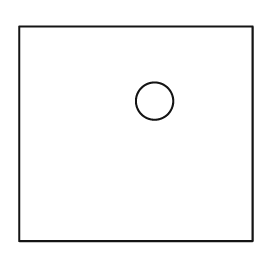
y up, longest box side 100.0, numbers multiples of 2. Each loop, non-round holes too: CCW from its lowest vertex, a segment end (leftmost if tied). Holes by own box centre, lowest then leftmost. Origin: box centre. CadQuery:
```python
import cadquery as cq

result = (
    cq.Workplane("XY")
    .moveTo(-50.0, -46.0)
    .lineTo(50.0, -46.0)
    .lineTo(50.0, 46.0)
    .lineTo(-50.0, 46.0)
    .close()
    .moveTo(8.0, 14.0)
    .circle(8.0)
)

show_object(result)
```